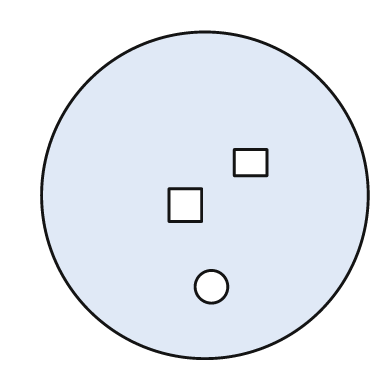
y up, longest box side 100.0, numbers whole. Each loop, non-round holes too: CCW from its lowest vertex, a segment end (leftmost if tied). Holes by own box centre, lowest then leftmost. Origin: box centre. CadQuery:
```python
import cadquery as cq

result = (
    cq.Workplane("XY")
    .moveTo(0.0, 0.0)
    .circle(50.0)
    .moveTo(2.0, -28.0)
    .circle(5.0)
    .moveTo(-11.0, -8.0)
    .lineTo(-1.0, -8.0)
    .lineTo(-1.0, 2.0)
    .lineTo(-11.0, 2.0)
    .close()
    .moveTo(9.0, 6.0)
    .lineTo(19.0, 6.0)
    .lineTo(19.0, 14.0)
    .lineTo(9.0, 14.0)
    .close()
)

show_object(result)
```